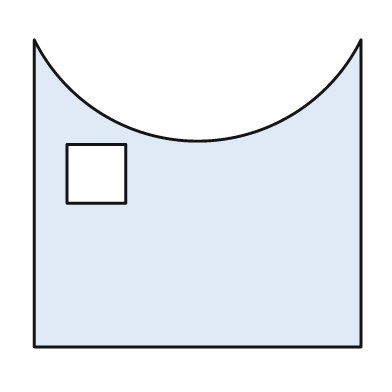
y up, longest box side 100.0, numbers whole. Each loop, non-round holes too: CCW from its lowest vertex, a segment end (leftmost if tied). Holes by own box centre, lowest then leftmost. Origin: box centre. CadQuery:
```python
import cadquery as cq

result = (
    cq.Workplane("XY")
    .moveTo(-50.0, -47.0)
    .lineTo(50.0, -47.0)
    .lineTo(50.0, 47.0)
    .threePointArc((0.0, 16.0), (-50.0, 47.0))
    .close()
    .moveTo(-40.0, -3.0)
    .lineTo(-22.0, -3.0)
    .lineTo(-22.0, 15.0)
    .lineTo(-40.0, 15.0)
    .close()
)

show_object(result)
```